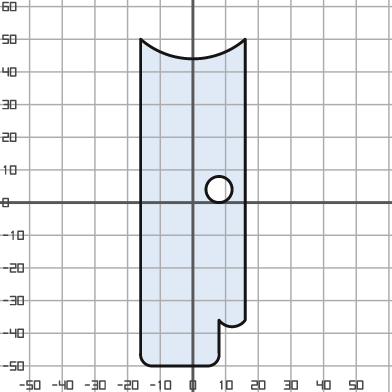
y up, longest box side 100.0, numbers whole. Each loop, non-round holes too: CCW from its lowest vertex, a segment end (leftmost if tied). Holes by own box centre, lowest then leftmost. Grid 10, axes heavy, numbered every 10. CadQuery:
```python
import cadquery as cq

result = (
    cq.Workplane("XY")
    .moveTo(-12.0, -50.0)
    .lineTo(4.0, -50.0)
    .threePointArc((7.0, -49.0), (8.0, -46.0))
    .lineTo(8.0, -36.0)
    .threePointArc((12.0, -38.0), (16.0, -36.0))
    .lineTo(16.0, 50.0)
    .threePointArc((0.0, 44.0), (-16.0, 50.0))
    .lineTo(-16.0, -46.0)
    .threePointArc((-15.0, -49.0), (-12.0, -50.0))
    .close()
    .moveTo(8.0, 4.0)
    .circle(4.0)
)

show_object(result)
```